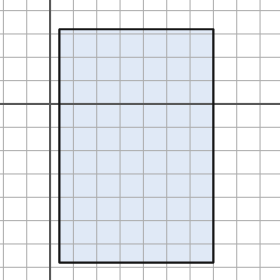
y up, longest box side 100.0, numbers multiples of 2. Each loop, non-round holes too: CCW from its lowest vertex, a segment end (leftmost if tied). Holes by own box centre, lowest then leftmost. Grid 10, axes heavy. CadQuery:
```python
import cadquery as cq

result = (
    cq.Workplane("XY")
    .moveTo(4.0, -68.0)
    .lineTo(70.0, -68.0)
    .lineTo(70.0, 32.0)
    .lineTo(4.0, 32.0)
    .close()
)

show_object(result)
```